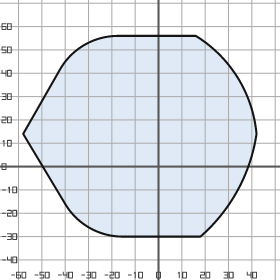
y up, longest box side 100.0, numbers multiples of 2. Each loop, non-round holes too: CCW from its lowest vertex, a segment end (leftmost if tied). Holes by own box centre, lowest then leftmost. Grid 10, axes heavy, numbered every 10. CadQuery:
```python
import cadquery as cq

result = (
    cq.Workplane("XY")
    .moveTo(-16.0, -30.0)
    .lineTo(18.0, -30.0)
    .threePointArc((34.0, -10.0), (42.0, 14.0))
    .threePointArc((34.0, 38.0), (16.0, 56.0))
    .lineTo(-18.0, 56.0)
    .threePointArc((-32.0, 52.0), (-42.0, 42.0))
    .lineTo(-58.0, 14.0)
    .lineTo(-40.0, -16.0)
    .threePointArc((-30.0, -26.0), (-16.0, -30.0))
    .close()
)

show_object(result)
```